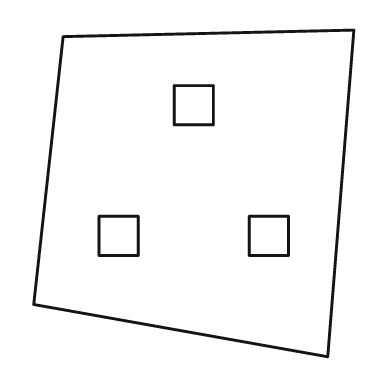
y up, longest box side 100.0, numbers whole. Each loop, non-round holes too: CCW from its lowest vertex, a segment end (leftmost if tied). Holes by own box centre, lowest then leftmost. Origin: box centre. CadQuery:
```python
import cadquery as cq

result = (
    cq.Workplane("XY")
    .moveTo(41.0, -50.0)
    .lineTo(49.0, 50.0)
    .lineTo(-40.0, 48.0)
    .lineTo(-49.0, -34.0)
    .close()
    .moveTo(-29.0, -19.0)
    .lineTo(-17.0, -19.0)
    .lineTo(-17.0, -7.0)
    .lineTo(-29.0, -7.0)
    .close()
    .moveTo(17.0, -19.0)
    .lineTo(29.0, -19.0)
    .lineTo(29.0, -7.0)
    .lineTo(17.0, -7.0)
    .close()
    .moveTo(-6.0, 21.0)
    .lineTo(6.0, 21.0)
    .lineTo(6.0, 33.0)
    .lineTo(-6.0, 33.0)
    .close()
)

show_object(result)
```